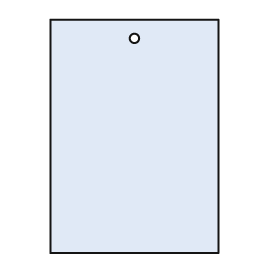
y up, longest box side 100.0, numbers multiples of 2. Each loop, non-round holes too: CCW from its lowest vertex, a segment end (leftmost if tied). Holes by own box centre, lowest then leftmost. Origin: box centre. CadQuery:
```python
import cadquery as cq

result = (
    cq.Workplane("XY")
    .moveTo(-36.0, -50.0)
    .lineTo(36.0, -50.0)
    .lineTo(36.0, 50.0)
    .lineTo(-36.0, 50.0)
    .close()
    .moveTo(0.0, 42.0)
    .circle(2.0)
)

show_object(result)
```